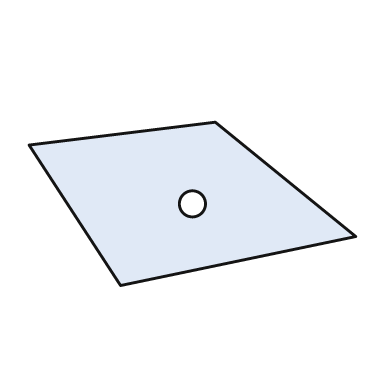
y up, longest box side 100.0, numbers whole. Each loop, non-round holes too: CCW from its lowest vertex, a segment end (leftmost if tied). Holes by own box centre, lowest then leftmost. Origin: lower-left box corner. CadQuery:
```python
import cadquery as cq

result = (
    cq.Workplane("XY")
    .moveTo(28.0, 0.0)
    .lineTo(100.0, 15.0)
    .lineTo(57.0, 50.0)
    .lineTo(0.0, 43.0)
    .close()
    .moveTo(50.0, 25.0)
    .circle(4.0)
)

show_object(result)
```